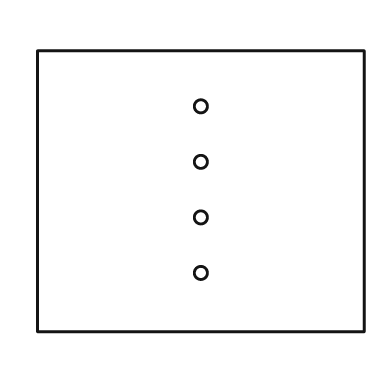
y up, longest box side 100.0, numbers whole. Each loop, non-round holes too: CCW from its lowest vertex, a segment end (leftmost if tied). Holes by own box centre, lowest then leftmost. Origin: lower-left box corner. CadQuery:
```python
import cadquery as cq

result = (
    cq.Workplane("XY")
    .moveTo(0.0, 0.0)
    .lineTo(100.0, 0.0)
    .lineTo(100.0, 86.0)
    .lineTo(0.0, 86.0)
    .close()
    .moveTo(50.0, 18.0)
    .circle(2.0)
    .moveTo(50.0, 35.0)
    .circle(2.0)
    .moveTo(50.0, 52.0)
    .circle(2.0)
    .moveTo(50.0, 69.0)
    .circle(2.0)
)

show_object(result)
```